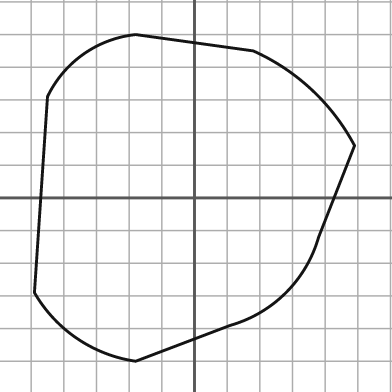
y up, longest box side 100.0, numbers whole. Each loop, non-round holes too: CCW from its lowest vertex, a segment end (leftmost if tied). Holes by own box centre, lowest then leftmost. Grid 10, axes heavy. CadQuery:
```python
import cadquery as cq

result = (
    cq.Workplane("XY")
    .moveTo(-18.0, -50.0)
    .lineTo(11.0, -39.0)
    .threePointArc((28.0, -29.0), (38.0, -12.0))
    .lineTo(49.0, 16.0)
    .threePointArc((36.0, 33.0), (18.0, 45.0))
    .lineTo(-18.0, 50.0)
    .threePointArc((-34.0, 44.0), (-45.0, 31.0))
    .lineTo(-49.0, -29.0)
    .threePointArc((-36.0, -43.0), (-18.0, -50.0))
    .close()
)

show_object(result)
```